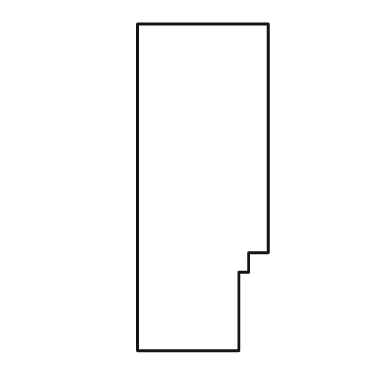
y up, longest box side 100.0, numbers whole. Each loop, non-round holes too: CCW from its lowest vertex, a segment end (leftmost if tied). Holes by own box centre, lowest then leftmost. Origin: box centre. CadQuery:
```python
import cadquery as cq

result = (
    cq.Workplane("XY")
    .moveTo(-20.0, -50.0)
    .lineTo(11.0, -50.0)
    .lineTo(11.0, -26.0)
    .lineTo(14.0, -26.0)
    .lineTo(14.0, -20.0)
    .lineTo(20.0, -20.0)
    .lineTo(20.0, 50.0)
    .lineTo(-20.0, 50.0)
    .close()
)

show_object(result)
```